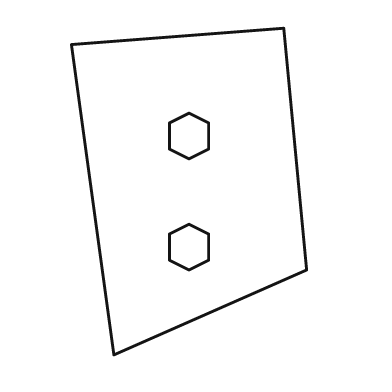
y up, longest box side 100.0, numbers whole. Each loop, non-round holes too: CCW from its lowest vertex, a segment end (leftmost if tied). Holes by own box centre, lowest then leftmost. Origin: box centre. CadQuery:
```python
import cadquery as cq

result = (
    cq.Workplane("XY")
    .moveTo(-23.0, -50.0)
    .lineTo(36.0, -24.0)
    .lineTo(29.0, 50.0)
    .lineTo(-36.0, 45.0)
    .close()
    .moveTo(0.0, -24.0)
    .lineTo(6.0, -21.0)
    .lineTo(6.0, -13.0)
    .lineTo(0.0, -10.0)
    .lineTo(-6.0, -13.0)
    .lineTo(-6.0, -21.0)
    .close()
    .moveTo(0.0, 10.0)
    .lineTo(6.0, 13.0)
    .lineTo(6.0, 21.0)
    .lineTo(0.0, 24.0)
    .lineTo(-6.0, 21.0)
    .lineTo(-6.0, 13.0)
    .close()
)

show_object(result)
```